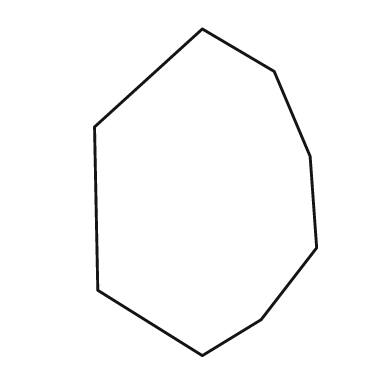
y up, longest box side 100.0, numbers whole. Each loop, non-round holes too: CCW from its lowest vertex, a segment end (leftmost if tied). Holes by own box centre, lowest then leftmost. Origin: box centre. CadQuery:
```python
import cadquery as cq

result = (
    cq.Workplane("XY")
    .moveTo(-1.0, -50.0)
    .lineTo(17.0, -39.0)
    .lineTo(34.0, -17.0)
    .lineTo(32.0, 11.0)
    .lineTo(21.0, 37.0)
    .lineTo(-1.0, 50.0)
    .lineTo(-34.0, 20.0)
    .lineTo(-33.0, -30.0)
    .close()
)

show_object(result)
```